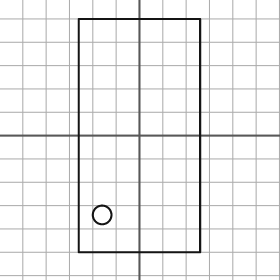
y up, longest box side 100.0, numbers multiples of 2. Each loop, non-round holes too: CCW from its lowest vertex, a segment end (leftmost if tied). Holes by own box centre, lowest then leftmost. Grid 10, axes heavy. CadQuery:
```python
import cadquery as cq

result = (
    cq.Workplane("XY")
    .moveTo(-26.0, -50.0)
    .lineTo(26.0, -50.0)
    .lineTo(26.0, 50.0)
    .lineTo(-26.0, 50.0)
    .close()
    .moveTo(-16.0, -34.0)
    .circle(4.0)
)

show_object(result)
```